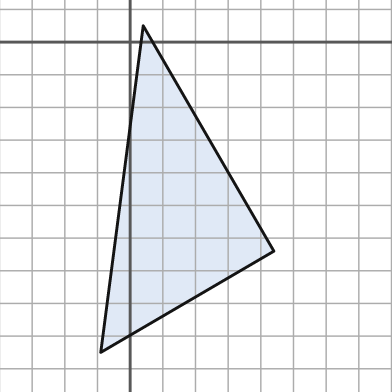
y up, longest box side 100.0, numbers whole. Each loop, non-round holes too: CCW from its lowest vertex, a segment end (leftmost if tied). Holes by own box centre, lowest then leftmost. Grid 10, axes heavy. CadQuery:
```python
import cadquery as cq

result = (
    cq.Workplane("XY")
    .moveTo(-9.0, -95.0)
    .lineTo(44.0, -64.0)
    .lineTo(4.0, 5.0)
    .close()
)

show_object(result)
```